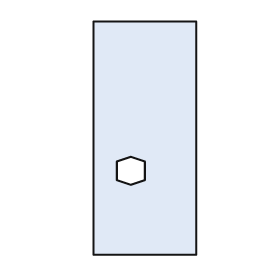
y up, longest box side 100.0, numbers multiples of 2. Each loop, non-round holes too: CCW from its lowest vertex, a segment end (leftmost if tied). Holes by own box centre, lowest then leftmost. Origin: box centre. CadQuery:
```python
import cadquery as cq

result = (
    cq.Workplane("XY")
    .moveTo(-22.0, -50.0)
    .lineTo(22.0, -50.0)
    .lineTo(22.0, 50.0)
    .lineTo(-22.0, 50.0)
    .close()
    .moveTo(-6.0, -20.0)
    .lineTo(0.0, -18.0)
    .lineTo(0.0, -10.0)
    .lineTo(-6.0, -8.0)
    .lineTo(-12.0, -10.0)
    .lineTo(-12.0, -18.0)
    .close()
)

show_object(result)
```